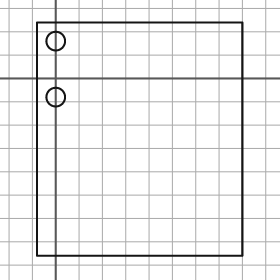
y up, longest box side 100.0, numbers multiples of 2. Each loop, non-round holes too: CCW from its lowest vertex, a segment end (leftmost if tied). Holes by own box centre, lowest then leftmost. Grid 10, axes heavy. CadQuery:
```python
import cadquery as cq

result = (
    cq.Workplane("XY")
    .moveTo(-8.0, -76.0)
    .lineTo(80.0, -76.0)
    .lineTo(80.0, 24.0)
    .lineTo(-8.0, 24.0)
    .close()
    .moveTo(0.0, -8.0)
    .circle(4.0)
    .moveTo(0.0, 16.0)
    .circle(4.0)
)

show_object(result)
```